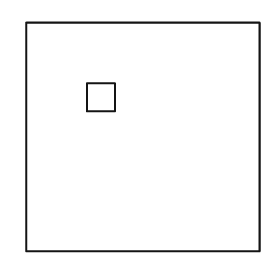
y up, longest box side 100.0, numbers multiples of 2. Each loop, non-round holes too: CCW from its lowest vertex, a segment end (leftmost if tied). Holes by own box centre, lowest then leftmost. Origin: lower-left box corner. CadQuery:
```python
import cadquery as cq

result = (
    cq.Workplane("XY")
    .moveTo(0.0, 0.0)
    .lineTo(100.0, 0.0)
    .lineTo(100.0, 98.0)
    .lineTo(0.0, 98.0)
    .close()
    .moveTo(26.0, 60.0)
    .lineTo(38.0, 60.0)
    .lineTo(38.0, 72.0)
    .lineTo(26.0, 72.0)
    .close()
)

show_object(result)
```